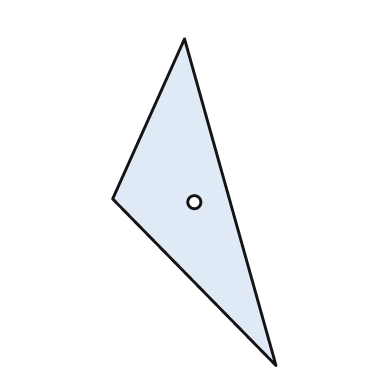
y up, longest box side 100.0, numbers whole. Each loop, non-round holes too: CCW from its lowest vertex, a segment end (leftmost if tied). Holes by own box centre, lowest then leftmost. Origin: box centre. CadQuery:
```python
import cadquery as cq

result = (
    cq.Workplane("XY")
    .moveTo(25.0, -50.0)
    .lineTo(-3.0, 50.0)
    .lineTo(-25.0, 1.0)
    .close()
    .moveTo(0.0, 0.0)
    .circle(2.0)
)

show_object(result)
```